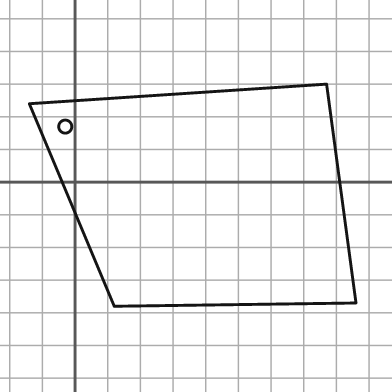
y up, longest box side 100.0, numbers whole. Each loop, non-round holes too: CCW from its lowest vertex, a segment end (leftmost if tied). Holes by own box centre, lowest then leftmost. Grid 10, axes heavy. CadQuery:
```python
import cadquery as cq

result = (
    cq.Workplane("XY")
    .moveTo(12.0, -38.0)
    .lineTo(86.0, -37.0)
    .lineTo(77.0, 30.0)
    .lineTo(-14.0, 24.0)
    .close()
    .moveTo(-3.0, 17.0)
    .circle(2.0)
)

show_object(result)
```